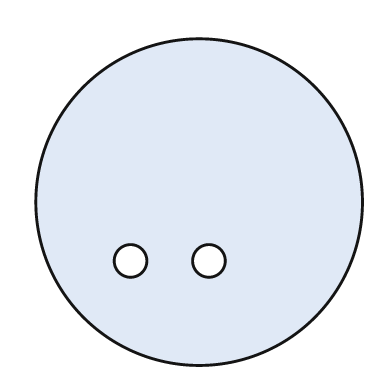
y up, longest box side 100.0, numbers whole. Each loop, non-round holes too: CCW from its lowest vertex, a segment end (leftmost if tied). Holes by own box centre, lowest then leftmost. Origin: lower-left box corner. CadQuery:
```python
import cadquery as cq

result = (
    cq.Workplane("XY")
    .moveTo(50.0, 50.0)
    .circle(50.0)
    .moveTo(29.0, 32.0)
    .circle(5.0)
    .moveTo(53.0, 32.0)
    .circle(5.0)
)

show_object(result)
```